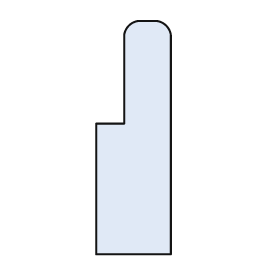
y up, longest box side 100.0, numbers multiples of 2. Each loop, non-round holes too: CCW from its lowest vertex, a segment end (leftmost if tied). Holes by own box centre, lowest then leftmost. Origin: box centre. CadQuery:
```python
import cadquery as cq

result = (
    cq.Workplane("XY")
    .moveTo(-16.0, -50.0)
    .lineTo(16.0, -50.0)
    .lineTo(16.0, 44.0)
    .threePointArc((14.0, 48.0), (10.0, 50.0))
    .lineTo(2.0, 50.0)
    .threePointArc((-2.0, 48.0), (-4.0, 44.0))
    .lineTo(-4.0, 6.0)
    .lineTo(-16.0, 6.0)
    .close()
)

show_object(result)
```